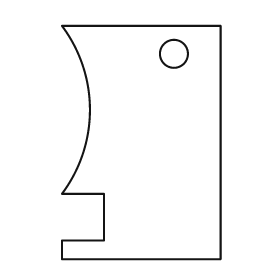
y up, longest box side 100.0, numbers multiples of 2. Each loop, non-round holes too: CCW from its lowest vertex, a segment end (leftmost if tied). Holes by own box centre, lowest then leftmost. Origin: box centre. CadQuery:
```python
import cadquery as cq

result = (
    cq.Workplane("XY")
    .moveTo(-34.0, -50.0)
    .lineTo(34.0, -50.0)
    .lineTo(34.0, 50.0)
    .lineTo(-34.0, 50.0)
    .threePointArc((-22.0, 14.0), (-34.0, -22.0))
    .lineTo(-16.0, -22.0)
    .lineTo(-16.0, -42.0)
    .lineTo(-34.0, -42.0)
    .close()
    .moveTo(14.0, 38.0)
    .circle(6.0)
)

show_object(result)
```